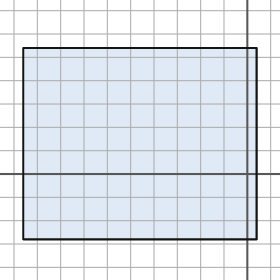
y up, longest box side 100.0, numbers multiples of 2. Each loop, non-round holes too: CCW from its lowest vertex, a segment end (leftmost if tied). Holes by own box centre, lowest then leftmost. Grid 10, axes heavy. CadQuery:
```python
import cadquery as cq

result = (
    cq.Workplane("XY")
    .moveTo(-96.0, -28.0)
    .lineTo(4.0, -28.0)
    .lineTo(4.0, 54.0)
    .lineTo(-96.0, 54.0)
    .close()
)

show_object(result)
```